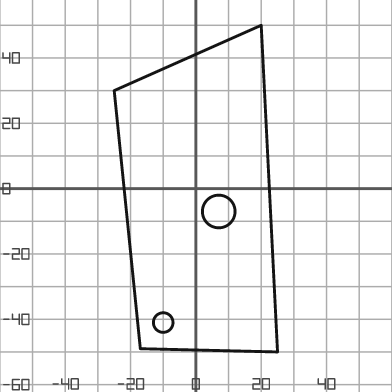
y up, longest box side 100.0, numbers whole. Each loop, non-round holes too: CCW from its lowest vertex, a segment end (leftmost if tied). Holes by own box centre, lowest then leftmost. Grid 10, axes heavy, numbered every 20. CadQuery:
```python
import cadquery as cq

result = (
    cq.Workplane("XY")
    .moveTo(25.0, -50.0)
    .lineTo(20.0, 50.0)
    .lineTo(-25.0, 30.0)
    .lineTo(-17.0, -49.0)
    .close()
    .moveTo(-10.0, -41.0)
    .circle(3.0)
    .moveTo(7.0, -7.0)
    .circle(5.0)
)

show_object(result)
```